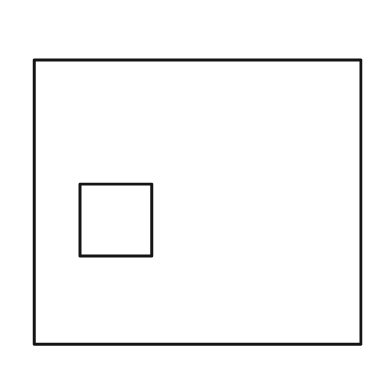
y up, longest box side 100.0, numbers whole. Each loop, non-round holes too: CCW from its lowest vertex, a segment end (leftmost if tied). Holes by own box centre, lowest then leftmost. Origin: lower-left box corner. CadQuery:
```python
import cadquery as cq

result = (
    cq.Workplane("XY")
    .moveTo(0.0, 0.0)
    .lineTo(100.0, 0.0)
    .lineTo(100.0, 87.0)
    .lineTo(0.0, 87.0)
    .close()
    .moveTo(14.0, 27.0)
    .lineTo(36.0, 27.0)
    .lineTo(36.0, 49.0)
    .lineTo(14.0, 49.0)
    .close()
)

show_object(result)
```